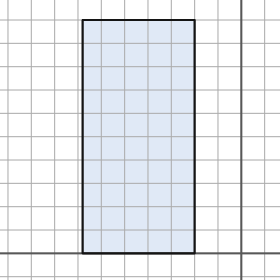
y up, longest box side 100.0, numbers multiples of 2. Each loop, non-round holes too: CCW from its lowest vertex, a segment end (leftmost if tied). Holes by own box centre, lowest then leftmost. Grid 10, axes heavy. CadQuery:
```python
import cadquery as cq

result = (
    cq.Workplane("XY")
    .moveTo(-68.0, 0.0)
    .lineTo(-20.0, 0.0)
    .lineTo(-20.0, 100.0)
    .lineTo(-68.0, 100.0)
    .close()
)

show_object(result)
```